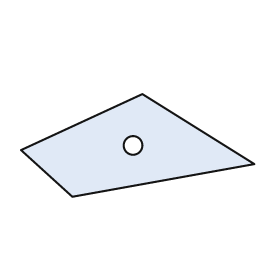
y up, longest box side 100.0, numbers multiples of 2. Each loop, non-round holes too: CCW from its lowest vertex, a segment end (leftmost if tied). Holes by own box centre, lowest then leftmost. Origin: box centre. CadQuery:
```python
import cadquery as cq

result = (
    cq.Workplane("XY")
    .moveTo(-28.0, -22.0)
    .lineTo(50.0, -8.0)
    .lineTo(2.0, 22.0)
    .lineTo(-50.0, -2.0)
    .close()
    .moveTo(-2.0, 0.0)
    .circle(4.0)
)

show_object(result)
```